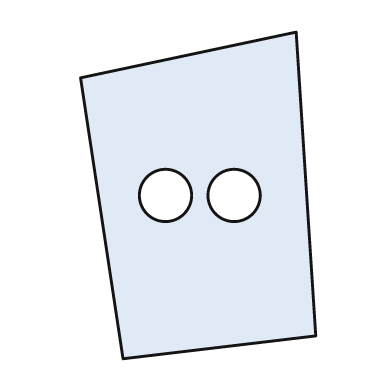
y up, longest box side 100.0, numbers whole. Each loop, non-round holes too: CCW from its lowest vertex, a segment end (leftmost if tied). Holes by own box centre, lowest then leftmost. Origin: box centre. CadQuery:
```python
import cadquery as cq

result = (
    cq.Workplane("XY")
    .moveTo(-23.0, -50.0)
    .lineTo(36.0, -43.0)
    .lineTo(30.0, 50.0)
    .lineTo(-36.0, 36.0)
    .close()
    .moveTo(-10.0, 0.0)
    .circle(8.0)
    .moveTo(11.0, 0.0)
    .circle(8.0)
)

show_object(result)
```